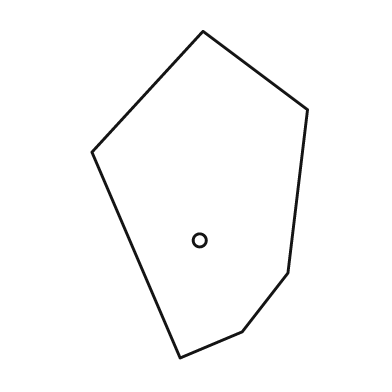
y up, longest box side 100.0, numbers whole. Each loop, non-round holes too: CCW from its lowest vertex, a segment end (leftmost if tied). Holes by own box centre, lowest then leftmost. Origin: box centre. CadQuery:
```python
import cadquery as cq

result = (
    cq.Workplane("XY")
    .moveTo(-6.0, -50.0)
    .lineTo(13.0, -42.0)
    .lineTo(27.0, -24.0)
    .lineTo(33.0, 26.0)
    .lineTo(1.0, 50.0)
    .lineTo(-33.0, 13.0)
    .close()
    .moveTo(0.0, -14.0)
    .circle(2.0)
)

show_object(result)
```